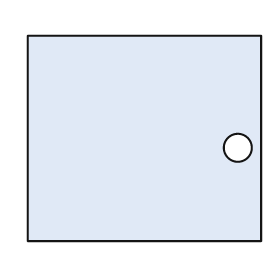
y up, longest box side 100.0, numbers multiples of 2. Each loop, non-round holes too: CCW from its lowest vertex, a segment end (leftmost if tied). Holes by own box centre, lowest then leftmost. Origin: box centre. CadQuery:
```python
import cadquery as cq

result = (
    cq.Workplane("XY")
    .moveTo(-50.0, -44.0)
    .lineTo(50.0, -44.0)
    .lineTo(50.0, 44.0)
    .lineTo(-50.0, 44.0)
    .close()
    .moveTo(40.0, -4.0)
    .circle(6.0)
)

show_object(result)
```